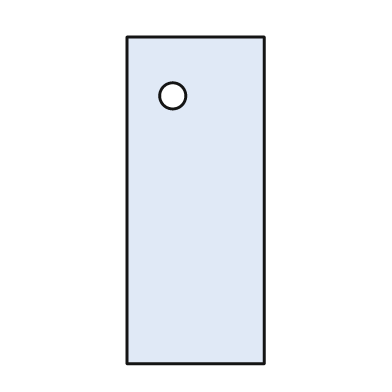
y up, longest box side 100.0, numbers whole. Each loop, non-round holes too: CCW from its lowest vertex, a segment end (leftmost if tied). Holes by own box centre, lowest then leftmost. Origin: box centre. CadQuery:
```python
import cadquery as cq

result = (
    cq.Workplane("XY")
    .moveTo(-21.0, -50.0)
    .lineTo(21.0, -50.0)
    .lineTo(21.0, 50.0)
    .lineTo(-21.0, 50.0)
    .close()
    .moveTo(-7.0, 32.0)
    .circle(4.0)
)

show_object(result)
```